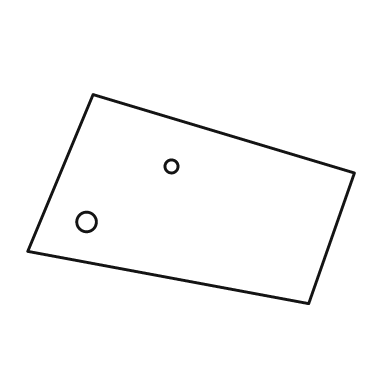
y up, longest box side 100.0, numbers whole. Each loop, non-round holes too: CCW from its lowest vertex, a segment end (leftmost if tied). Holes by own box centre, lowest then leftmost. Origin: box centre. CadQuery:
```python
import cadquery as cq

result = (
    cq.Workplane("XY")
    .moveTo(36.0, -32.0)
    .lineTo(50.0, 8.0)
    .lineTo(-30.0, 32.0)
    .lineTo(-50.0, -16.0)
    .close()
    .moveTo(-32.0, -7.0)
    .circle(3.0)
    .moveTo(-6.0, 10.0)
    .circle(2.0)
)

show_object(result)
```